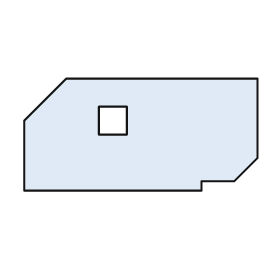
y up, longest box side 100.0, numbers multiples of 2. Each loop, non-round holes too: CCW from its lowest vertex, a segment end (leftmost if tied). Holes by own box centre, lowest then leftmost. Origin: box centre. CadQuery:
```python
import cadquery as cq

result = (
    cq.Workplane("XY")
    .moveTo(-50.0, -24.0)
    .lineTo(26.0, -24.0)
    .lineTo(26.0, -20.0)
    .lineTo(40.0, -20.0)
    .lineTo(50.0, -10.0)
    .lineTo(50.0, 24.0)
    .lineTo(-32.0, 24.0)
    .lineTo(-50.0, 6.0)
    .close()
    .moveTo(-18.0, 0.0)
    .lineTo(-6.0, 0.0)
    .lineTo(-6.0, 12.0)
    .lineTo(-18.0, 12.0)
    .close()
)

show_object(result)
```